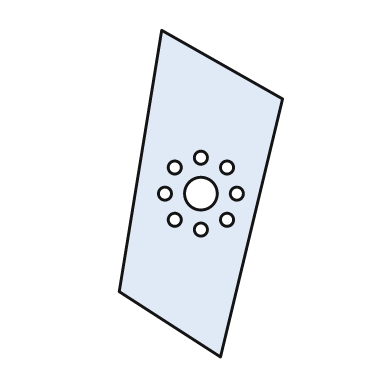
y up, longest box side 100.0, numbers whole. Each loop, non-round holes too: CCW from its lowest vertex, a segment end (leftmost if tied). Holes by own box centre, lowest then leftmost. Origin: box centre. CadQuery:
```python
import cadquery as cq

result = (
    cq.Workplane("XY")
    .moveTo(6.0, -50.0)
    .lineTo(25.0, 29.0)
    .lineTo(-12.0, 50.0)
    .lineTo(-25.0, -30.0)
    .close()
    .moveTo(0.0, -11.0)
    .circle(2.0)
    .moveTo(-8.0, -8.0)
    .circle(2.0)
    .moveTo(8.0, -8.0)
    .circle(2.0)
    .moveTo(-11.0, 0.0)
    .circle(2.0)
    .moveTo(0.0, 0.0)
    .circle(5.0)
    .moveTo(11.0, 0.0)
    .circle(2.0)
    .moveTo(-8.0, 8.0)
    .circle(2.0)
    .moveTo(8.0, 8.0)
    .circle(2.0)
    .moveTo(0.0, 11.0)
    .circle(2.0)
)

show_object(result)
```